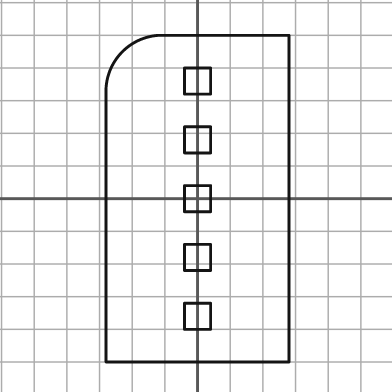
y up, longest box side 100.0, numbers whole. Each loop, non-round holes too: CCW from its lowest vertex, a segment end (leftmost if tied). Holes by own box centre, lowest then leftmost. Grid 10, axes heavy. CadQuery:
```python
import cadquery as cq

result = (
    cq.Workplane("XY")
    .moveTo(-28.0, -50.0)
    .lineTo(28.0, -50.0)
    .lineTo(28.0, 50.0)
    .lineTo(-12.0, 50.0)
    .threePointArc((-23.0, 45.0), (-28.0, 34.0))
    .close()
    .moveTo(-4.0, -40.0)
    .lineTo(4.0, -40.0)
    .lineTo(4.0, -32.0)
    .lineTo(-4.0, -32.0)
    .close()
    .moveTo(-4.0, -22.0)
    .lineTo(4.0, -22.0)
    .lineTo(4.0, -14.0)
    .lineTo(-4.0, -14.0)
    .close()
    .moveTo(-4.0, -4.0)
    .lineTo(4.0, -4.0)
    .lineTo(4.0, 4.0)
    .lineTo(-4.0, 4.0)
    .close()
    .moveTo(-4.0, 14.0)
    .lineTo(4.0, 14.0)
    .lineTo(4.0, 22.0)
    .lineTo(-4.0, 22.0)
    .close()
    .moveTo(-4.0, 32.0)
    .lineTo(4.0, 32.0)
    .lineTo(4.0, 40.0)
    .lineTo(-4.0, 40.0)
    .close()
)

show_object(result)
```